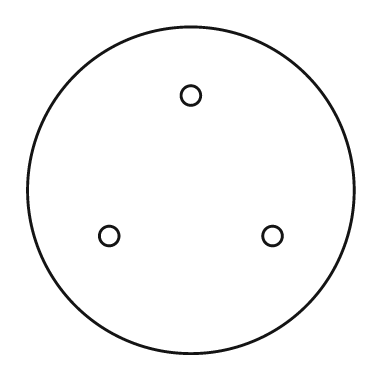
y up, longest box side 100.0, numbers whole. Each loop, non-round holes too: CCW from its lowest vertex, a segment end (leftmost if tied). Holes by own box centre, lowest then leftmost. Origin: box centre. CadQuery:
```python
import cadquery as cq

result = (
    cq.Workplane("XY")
    .moveTo(0.0, 0.0)
    .circle(50.0)
    .moveTo(-25.0, -14.0)
    .circle(3.0)
    .moveTo(25.0, -14.0)
    .circle(3.0)
    .moveTo(0.0, 29.0)
    .circle(3.0)
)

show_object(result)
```